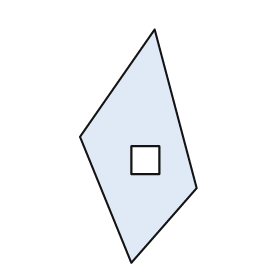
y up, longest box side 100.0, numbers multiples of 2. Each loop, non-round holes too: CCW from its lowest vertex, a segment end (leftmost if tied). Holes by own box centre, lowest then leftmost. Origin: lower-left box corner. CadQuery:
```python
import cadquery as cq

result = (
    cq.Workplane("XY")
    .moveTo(22.0, 0.0)
    .lineTo(50.0, 32.0)
    .lineTo(32.0, 100.0)
    .lineTo(0.0, 54.0)
    .close()
    .moveTo(22.0, 38.0)
    .lineTo(34.0, 38.0)
    .lineTo(34.0, 50.0)
    .lineTo(22.0, 50.0)
    .close()
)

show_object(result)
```